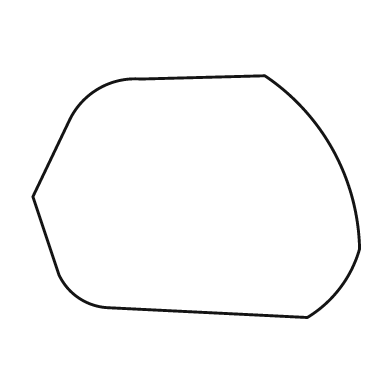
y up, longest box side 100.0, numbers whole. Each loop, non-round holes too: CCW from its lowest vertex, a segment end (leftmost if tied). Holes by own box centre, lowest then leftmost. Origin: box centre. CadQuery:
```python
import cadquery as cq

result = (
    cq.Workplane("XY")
    .moveTo(34.0, -37.0)
    .threePointArc((44.0, -28.0), (50.0, -16.0))
    .threePointArc((42.0, 14.0), (21.0, 37.0))
    .lineTo(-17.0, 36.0)
    .threePointArc((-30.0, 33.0), (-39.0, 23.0))
    .lineTo(-50.0, 0.0)
    .lineTo(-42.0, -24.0)
    .threePointArc((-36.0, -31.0), (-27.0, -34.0))
    .close()
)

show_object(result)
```